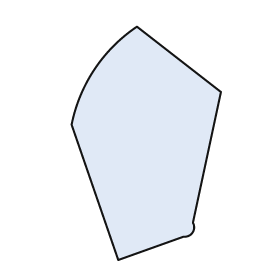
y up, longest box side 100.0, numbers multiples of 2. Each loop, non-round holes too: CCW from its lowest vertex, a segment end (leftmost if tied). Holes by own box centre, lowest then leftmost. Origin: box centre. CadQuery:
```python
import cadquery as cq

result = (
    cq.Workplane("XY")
    .moveTo(-12.0, -50.0)
    .lineTo(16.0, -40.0)
    .threePointArc((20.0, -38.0), (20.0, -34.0))
    .lineTo(32.0, 22.0)
    .lineTo(-4.0, 50.0)
    .threePointArc((-22.0, 32.0), (-32.0, 8.0))
    .close()
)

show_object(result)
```